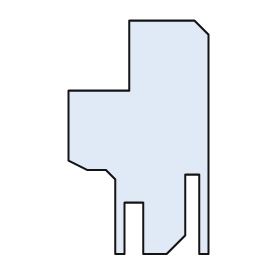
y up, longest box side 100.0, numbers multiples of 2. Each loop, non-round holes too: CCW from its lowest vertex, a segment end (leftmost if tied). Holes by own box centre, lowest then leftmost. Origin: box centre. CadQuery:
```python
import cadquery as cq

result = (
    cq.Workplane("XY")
    .moveTo(-10.0, -50.0)
    .lineTo(-6.0, -50.0)
    .lineTo(-6.0, -28.0)
    .lineTo(2.0, -28.0)
    .lineTo(2.0, -50.0)
    .lineTo(12.0, -50.0)
    .lineTo(20.0, -42.0)
    .lineTo(20.0, -16.0)
    .lineTo(26.0, -16.0)
    .lineTo(26.0, -50.0)
    .lineTo(30.0, -50.0)
    .lineTo(30.0, 44.0)
    .lineTo(24.0, 50.0)
    .lineTo(-4.0, 50.0)
    .lineTo(-4.0, 20.0)
    .lineTo(-30.0, 20.0)
    .lineTo(-30.0, -10.0)
    .lineTo(-22.0, -14.0)
    .lineTo(-14.0, -14.0)
    .lineTo(-10.0, -18.0)
    .close()
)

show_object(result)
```